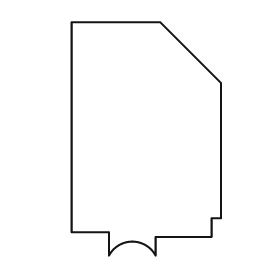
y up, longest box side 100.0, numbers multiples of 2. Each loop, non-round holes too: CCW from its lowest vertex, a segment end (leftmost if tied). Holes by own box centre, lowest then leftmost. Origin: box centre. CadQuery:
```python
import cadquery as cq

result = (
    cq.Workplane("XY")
    .moveTo(-16.0, -50.0)
    .threePointArc((-6.0, -44.0), (4.0, -50.0))
    .lineTo(4.0, -42.0)
    .lineTo(28.0, -42.0)
    .lineTo(28.0, -34.0)
    .lineTo(32.0, -34.0)
    .lineTo(32.0, 24.0)
    .lineTo(6.0, 50.0)
    .lineTo(-32.0, 50.0)
    .lineTo(-32.0, -40.0)
    .lineTo(-16.0, -40.0)
    .close()
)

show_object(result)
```